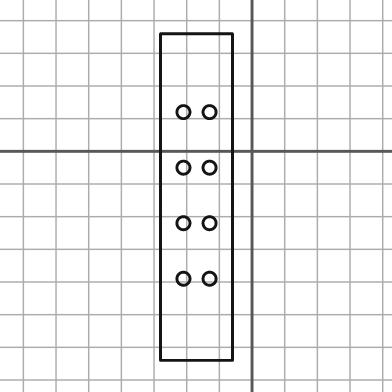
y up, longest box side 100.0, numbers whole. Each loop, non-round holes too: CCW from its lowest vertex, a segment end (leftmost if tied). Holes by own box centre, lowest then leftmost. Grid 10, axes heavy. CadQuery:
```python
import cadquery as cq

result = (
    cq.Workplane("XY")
    .moveTo(-28.0, -64.0)
    .lineTo(-6.0, -64.0)
    .lineTo(-6.0, 36.0)
    .lineTo(-28.0, 36.0)
    .close()
    .moveTo(-21.0, -39.0)
    .circle(2.0)
    .moveTo(-13.0, -39.0)
    .circle(2.0)
    .moveTo(-21.0, -22.0)
    .circle(2.0)
    .moveTo(-13.0, -22.0)
    .circle(2.0)
    .moveTo(-21.0, -5.0)
    .circle(2.0)
    .moveTo(-13.0, -5.0)
    .circle(2.0)
    .moveTo(-21.0, 12.0)
    .circle(2.0)
    .moveTo(-13.0, 12.0)
    .circle(2.0)
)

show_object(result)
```